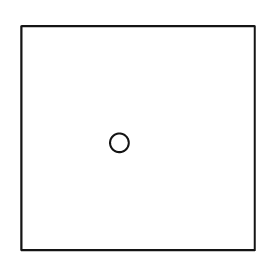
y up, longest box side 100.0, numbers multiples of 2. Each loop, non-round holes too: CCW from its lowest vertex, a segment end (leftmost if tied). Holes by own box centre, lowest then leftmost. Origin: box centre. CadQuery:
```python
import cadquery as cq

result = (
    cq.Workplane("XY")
    .moveTo(-50.0, -48.0)
    .lineTo(50.0, -48.0)
    .lineTo(50.0, 48.0)
    .lineTo(-50.0, 48.0)
    .close()
    .moveTo(-8.0, -2.0)
    .circle(4.0)
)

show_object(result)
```